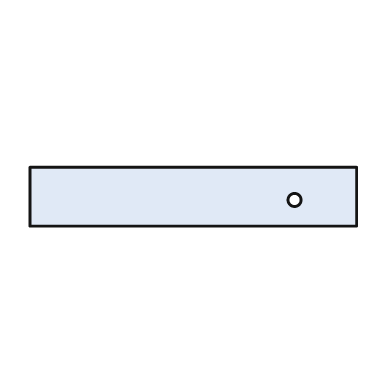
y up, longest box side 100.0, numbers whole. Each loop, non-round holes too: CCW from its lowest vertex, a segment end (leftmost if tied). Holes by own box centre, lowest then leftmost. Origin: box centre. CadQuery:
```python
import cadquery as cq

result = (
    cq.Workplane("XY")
    .moveTo(-50.0, -9.0)
    .lineTo(50.0, -9.0)
    .lineTo(50.0, 9.0)
    .lineTo(-50.0, 9.0)
    .close()
    .moveTo(31.0, -1.0)
    .circle(2.0)
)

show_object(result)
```